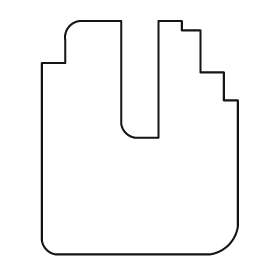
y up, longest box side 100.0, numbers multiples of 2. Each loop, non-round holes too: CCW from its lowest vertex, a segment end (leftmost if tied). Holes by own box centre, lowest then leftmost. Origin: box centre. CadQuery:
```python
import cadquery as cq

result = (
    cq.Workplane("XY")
    .moveTo(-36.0, -50.0)
    .lineTo(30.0, -50.0)
    .threePointArc((38.0, -46.0), (42.0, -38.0))
    .lineTo(42.0, 16.0)
    .lineTo(36.0, 16.0)
    .lineTo(36.0, 28.0)
    .lineTo(26.0, 28.0)
    .lineTo(26.0, 46.0)
    .lineTo(18.0, 46.0)
    .lineTo(18.0, 50.0)
    .lineTo(8.0, 50.0)
    .lineTo(8.0, 0.0)
    .lineTo(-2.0, 0.0)
    .threePointArc((-6.0, 2.0), (-8.0, 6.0))
    .lineTo(-8.0, 50.0)
    .lineTo(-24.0, 50.0)
    .threePointArc((-30.0, 48.0), (-32.0, 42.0))
    .lineTo(-32.0, 32.0)
    .lineTo(-42.0, 32.0)
    .lineTo(-42.0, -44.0)
    .threePointArc((-40.0, -48.0), (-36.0, -50.0))
    .close()
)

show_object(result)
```